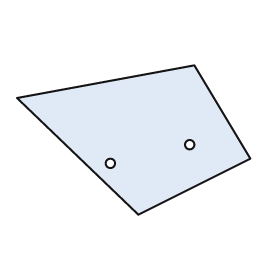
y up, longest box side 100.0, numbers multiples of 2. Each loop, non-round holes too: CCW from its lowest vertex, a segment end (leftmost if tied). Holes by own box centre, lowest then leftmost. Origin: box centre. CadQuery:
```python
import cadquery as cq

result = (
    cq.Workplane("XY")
    .moveTo(2.0, -32.0)
    .lineTo(50.0, -8.0)
    .lineTo(26.0, 32.0)
    .lineTo(-50.0, 18.0)
    .close()
    .moveTo(-10.0, -10.0)
    .circle(2.0)
    .moveTo(24.0, -2.0)
    .circle(2.0)
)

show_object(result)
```